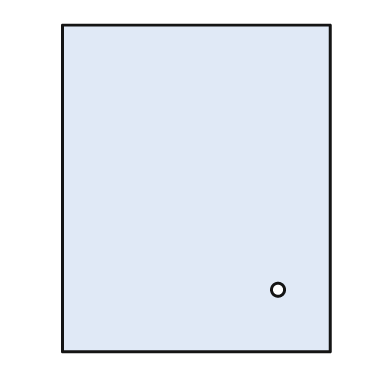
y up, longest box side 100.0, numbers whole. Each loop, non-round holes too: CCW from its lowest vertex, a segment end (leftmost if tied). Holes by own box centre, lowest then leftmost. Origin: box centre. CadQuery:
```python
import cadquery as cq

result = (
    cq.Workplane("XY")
    .moveTo(-41.0, -50.0)
    .lineTo(41.0, -50.0)
    .lineTo(41.0, 50.0)
    .lineTo(-41.0, 50.0)
    .close()
    .moveTo(25.0, -31.0)
    .circle(2.0)
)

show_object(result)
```